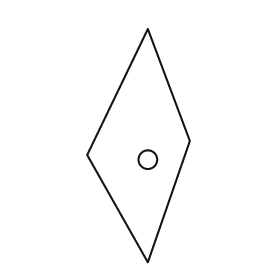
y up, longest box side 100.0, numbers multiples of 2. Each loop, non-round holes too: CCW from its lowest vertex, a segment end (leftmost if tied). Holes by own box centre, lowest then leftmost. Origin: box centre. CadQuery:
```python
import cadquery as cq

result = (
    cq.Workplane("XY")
    .moveTo(4.0, -50.0)
    .lineTo(22.0, 2.0)
    .lineTo(4.0, 50.0)
    .lineTo(-22.0, -4.0)
    .close()
    .moveTo(4.0, -6.0)
    .circle(4.0)
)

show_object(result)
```